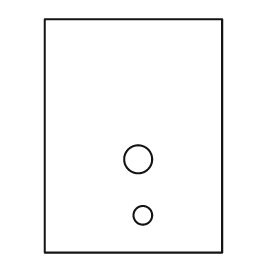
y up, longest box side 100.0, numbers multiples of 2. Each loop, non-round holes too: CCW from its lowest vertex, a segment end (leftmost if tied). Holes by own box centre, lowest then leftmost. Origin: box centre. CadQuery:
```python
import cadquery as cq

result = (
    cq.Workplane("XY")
    .moveTo(-38.0, -50.0)
    .lineTo(38.0, -50.0)
    .lineTo(38.0, 50.0)
    .lineTo(-38.0, 50.0)
    .close()
    .moveTo(4.0, -34.0)
    .circle(4.0)
    .moveTo(2.0, -10.0)
    .circle(6.0)
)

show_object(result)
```